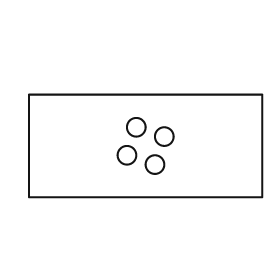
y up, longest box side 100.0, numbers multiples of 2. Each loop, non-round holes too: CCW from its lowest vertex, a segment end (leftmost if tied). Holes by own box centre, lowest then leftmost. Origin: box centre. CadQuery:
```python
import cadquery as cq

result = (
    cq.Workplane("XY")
    .moveTo(-50.0, -22.0)
    .lineTo(50.0, -22.0)
    .lineTo(50.0, 22.0)
    .lineTo(-50.0, 22.0)
    .close()
    .moveTo(4.0, -8.0)
    .circle(4.0)
    .moveTo(-8.0, -4.0)
    .circle(4.0)
    .moveTo(8.0, 4.0)
    .circle(4.0)
    .moveTo(-4.0, 8.0)
    .circle(4.0)
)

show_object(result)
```